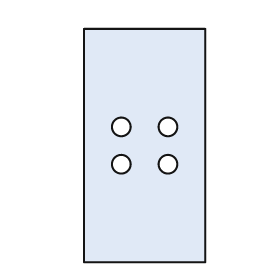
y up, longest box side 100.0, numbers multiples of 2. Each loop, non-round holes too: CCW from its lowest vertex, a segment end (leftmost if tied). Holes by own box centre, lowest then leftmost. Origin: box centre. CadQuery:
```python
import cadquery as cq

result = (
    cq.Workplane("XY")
    .moveTo(-26.0, -50.0)
    .lineTo(26.0, -50.0)
    .lineTo(26.0, 50.0)
    .lineTo(-26.0, 50.0)
    .close()
    .moveTo(-10.0, -8.0)
    .circle(4.0)
    .moveTo(10.0, -8.0)
    .circle(4.0)
    .moveTo(-10.0, 8.0)
    .circle(4.0)
    .moveTo(10.0, 8.0)
    .circle(4.0)
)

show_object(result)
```